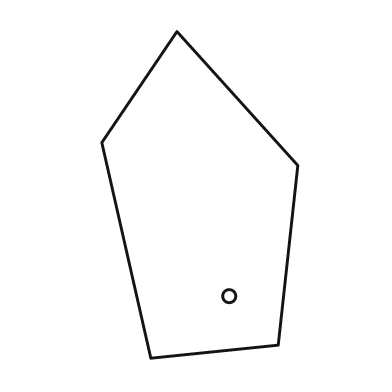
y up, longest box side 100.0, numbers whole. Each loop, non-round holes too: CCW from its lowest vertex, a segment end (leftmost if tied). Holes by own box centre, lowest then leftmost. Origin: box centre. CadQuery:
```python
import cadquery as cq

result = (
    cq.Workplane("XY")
    .moveTo(-15.0, -50.0)
    .lineTo(24.0, -46.0)
    .lineTo(30.0, 9.0)
    .lineTo(-7.0, 50.0)
    .lineTo(-30.0, 16.0)
    .close()
    .moveTo(9.0, -31.0)
    .circle(2.0)
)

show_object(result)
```